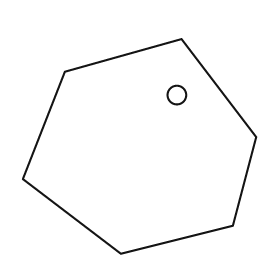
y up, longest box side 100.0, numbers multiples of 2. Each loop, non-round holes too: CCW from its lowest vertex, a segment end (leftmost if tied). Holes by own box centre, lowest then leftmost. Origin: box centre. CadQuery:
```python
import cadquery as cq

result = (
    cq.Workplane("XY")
    .moveTo(-8.0, -46.0)
    .lineTo(40.0, -34.0)
    .lineTo(50.0, 4.0)
    .lineTo(18.0, 46.0)
    .lineTo(-32.0, 32.0)
    .lineTo(-50.0, -14.0)
    .close()
    .moveTo(16.0, 22.0)
    .circle(4.0)
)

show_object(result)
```